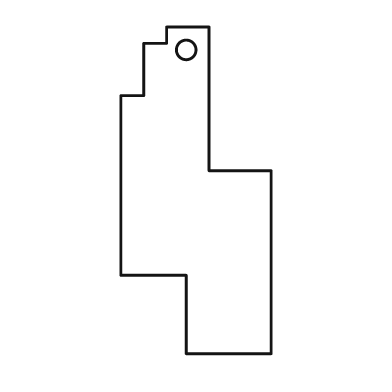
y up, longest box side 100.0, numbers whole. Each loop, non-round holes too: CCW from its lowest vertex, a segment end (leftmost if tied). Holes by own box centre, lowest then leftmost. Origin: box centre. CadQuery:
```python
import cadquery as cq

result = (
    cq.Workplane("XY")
    .moveTo(-3.0, -50.0)
    .lineTo(23.0, -50.0)
    .lineTo(23.0, 6.0)
    .lineTo(4.0, 6.0)
    .lineTo(4.0, 50.0)
    .lineTo(-9.0, 50.0)
    .lineTo(-9.0, 45.0)
    .lineTo(-16.0, 45.0)
    .lineTo(-16.0, 29.0)
    .lineTo(-23.0, 29.0)
    .lineTo(-23.0, -26.0)
    .lineTo(-3.0, -26.0)
    .close()
    .moveTo(-3.0, 43.0)
    .circle(3.0)
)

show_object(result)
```